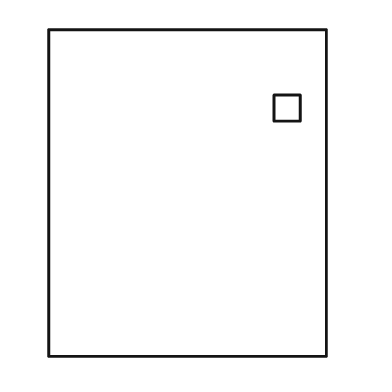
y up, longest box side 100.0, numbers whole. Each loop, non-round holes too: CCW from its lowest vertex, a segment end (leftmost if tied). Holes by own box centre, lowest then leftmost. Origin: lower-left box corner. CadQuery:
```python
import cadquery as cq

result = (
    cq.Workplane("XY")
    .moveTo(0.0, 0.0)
    .lineTo(85.0, 0.0)
    .lineTo(85.0, 100.0)
    .lineTo(0.0, 100.0)
    .close()
    .moveTo(69.0, 72.0)
    .lineTo(77.0, 72.0)
    .lineTo(77.0, 80.0)
    .lineTo(69.0, 80.0)
    .close()
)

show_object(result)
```